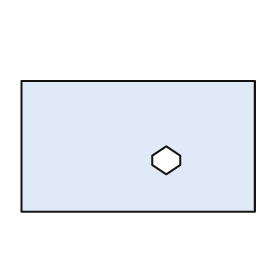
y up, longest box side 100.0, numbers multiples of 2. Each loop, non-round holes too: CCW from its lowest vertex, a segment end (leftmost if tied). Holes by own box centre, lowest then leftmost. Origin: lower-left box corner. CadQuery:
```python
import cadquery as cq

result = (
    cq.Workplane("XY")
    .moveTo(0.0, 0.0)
    .lineTo(100.0, 0.0)
    .lineTo(100.0, 56.0)
    .lineTo(0.0, 56.0)
    .close()
    .moveTo(62.0, 16.0)
    .lineTo(68.0, 20.0)
    .lineTo(68.0, 24.0)
    .lineTo(62.0, 28.0)
    .lineTo(56.0, 24.0)
    .lineTo(56.0, 20.0)
    .close()
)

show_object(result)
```